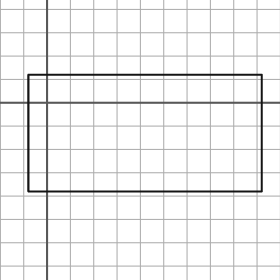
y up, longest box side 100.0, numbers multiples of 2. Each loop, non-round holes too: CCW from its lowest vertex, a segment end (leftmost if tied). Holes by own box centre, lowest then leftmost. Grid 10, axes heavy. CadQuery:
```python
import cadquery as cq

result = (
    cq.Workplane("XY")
    .moveTo(-8.0, -38.0)
    .lineTo(92.0, -38.0)
    .lineTo(92.0, 12.0)
    .lineTo(-8.0, 12.0)
    .close()
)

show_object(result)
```